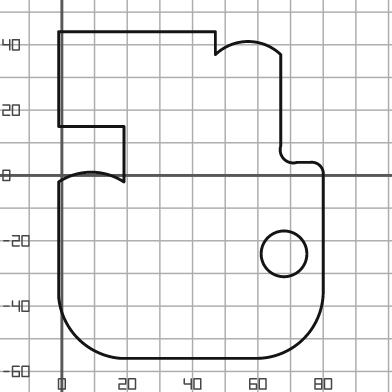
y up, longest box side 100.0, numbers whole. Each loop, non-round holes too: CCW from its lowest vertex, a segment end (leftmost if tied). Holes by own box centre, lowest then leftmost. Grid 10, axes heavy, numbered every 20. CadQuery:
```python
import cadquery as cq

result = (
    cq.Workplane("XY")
    .moveTo(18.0, -56.0)
    .lineTo(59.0, -56.0)
    .threePointArc((74.0, -50.0), (80.0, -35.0))
    .lineTo(80.0, 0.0)
    .threePointArc((79.0, 3.0), (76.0, 4.0))
    .lineTo(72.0, 4.0)
    .threePointArc((68.0, 5.0), (67.0, 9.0))
    .lineTo(67.0, 37.0)
    .threePointArc((57.0, 41.0), (47.0, 37.0))
    .lineTo(47.0, 44.0)
    .lineTo(-1.0, 44.0)
    .lineTo(-1.0, 15.0)
    .lineTo(19.0, 15.0)
    .lineTo(19.0, -2.0)
    .threePointArc((9.0, 1.0), (-1.0, -2.0))
    .lineTo(-1.0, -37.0)
    .threePointArc((5.0, -50.0), (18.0, -56.0))
    .close()
    .moveTo(68.0, -24.0)
    .circle(7.0)
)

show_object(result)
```